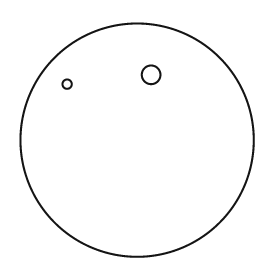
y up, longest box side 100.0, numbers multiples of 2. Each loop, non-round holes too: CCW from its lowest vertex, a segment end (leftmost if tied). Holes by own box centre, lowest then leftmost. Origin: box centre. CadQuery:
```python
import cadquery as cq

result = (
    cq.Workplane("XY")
    .moveTo(0.0, 0.0)
    .circle(50.0)
    .moveTo(-30.0, 24.0)
    .circle(2.0)
    .moveTo(6.0, 28.0)
    .circle(4.0)
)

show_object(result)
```